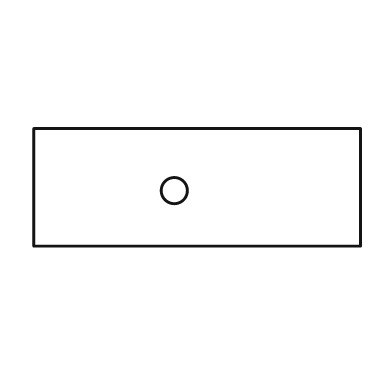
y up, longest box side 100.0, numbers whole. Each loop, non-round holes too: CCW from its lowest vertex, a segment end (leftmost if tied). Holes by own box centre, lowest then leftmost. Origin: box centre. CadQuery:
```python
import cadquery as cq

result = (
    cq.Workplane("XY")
    .moveTo(-50.0, -18.0)
    .lineTo(50.0, -18.0)
    .lineTo(50.0, 18.0)
    .lineTo(-50.0, 18.0)
    .close()
    .moveTo(-7.0, -1.0)
    .circle(4.0)
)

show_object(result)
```